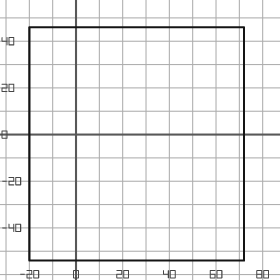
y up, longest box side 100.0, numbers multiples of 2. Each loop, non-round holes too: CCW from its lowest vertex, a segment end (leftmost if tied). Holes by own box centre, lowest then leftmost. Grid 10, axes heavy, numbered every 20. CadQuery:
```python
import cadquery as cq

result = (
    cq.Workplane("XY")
    .moveTo(-20.0, -54.0)
    .lineTo(72.0, -54.0)
    .lineTo(72.0, 46.0)
    .lineTo(-20.0, 46.0)
    .close()
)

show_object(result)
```